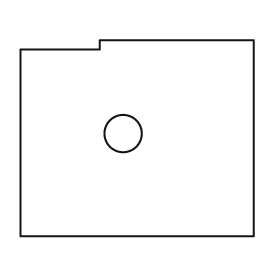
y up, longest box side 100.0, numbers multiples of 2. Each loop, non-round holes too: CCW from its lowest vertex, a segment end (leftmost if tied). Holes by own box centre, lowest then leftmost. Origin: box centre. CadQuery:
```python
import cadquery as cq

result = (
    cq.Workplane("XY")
    .moveTo(-50.0, -42.0)
    .lineTo(50.0, -42.0)
    .lineTo(50.0, 42.0)
    .lineTo(-16.0, 42.0)
    .lineTo(-16.0, 38.0)
    .lineTo(-50.0, 38.0)
    .close()
    .moveTo(-6.0, 2.0)
    .circle(8.0)
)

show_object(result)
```